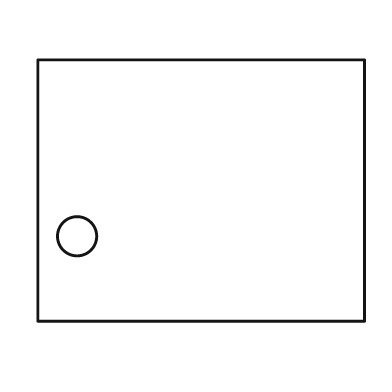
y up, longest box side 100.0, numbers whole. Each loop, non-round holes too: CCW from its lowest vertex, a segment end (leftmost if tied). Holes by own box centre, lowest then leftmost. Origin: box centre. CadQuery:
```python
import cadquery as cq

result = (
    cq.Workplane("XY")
    .moveTo(-50.0, -40.0)
    .lineTo(50.0, -40.0)
    .lineTo(50.0, 40.0)
    .lineTo(-50.0, 40.0)
    .close()
    .moveTo(-38.0, -14.0)
    .circle(6.0)
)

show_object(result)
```